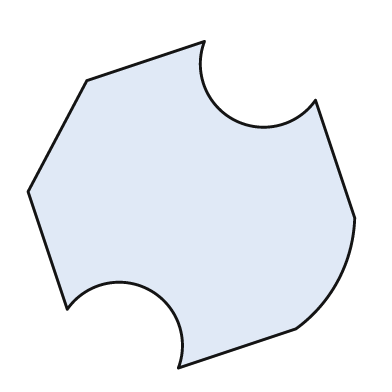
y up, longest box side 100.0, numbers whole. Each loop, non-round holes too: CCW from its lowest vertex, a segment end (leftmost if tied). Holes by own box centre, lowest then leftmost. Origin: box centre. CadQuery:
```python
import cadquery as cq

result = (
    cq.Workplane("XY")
    .moveTo(-4.0, -50.0)
    .lineTo(32.0, -38.0)
    .threePointArc((45.0, -23.0), (50.0, -4.0))
    .lineTo(38.0, 32.0)
    .threePointArc((13.0, 26.0), (4.0, 50.0))
    .lineTo(-32.0, 38.0)
    .lineTo(-50.0, 4.0)
    .lineTo(-38.0, -32.0)
    .threePointArc((-13.0, -26.0), (-4.0, -50.0))
    .close()
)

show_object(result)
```